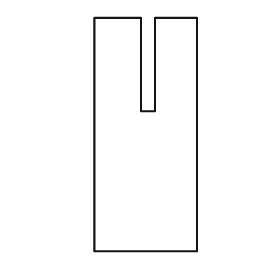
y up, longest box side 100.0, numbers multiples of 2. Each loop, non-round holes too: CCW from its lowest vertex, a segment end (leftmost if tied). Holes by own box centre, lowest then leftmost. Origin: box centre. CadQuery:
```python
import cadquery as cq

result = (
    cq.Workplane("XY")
    .moveTo(-22.0, -50.0)
    .lineTo(22.0, -50.0)
    .lineTo(22.0, 50.0)
    .lineTo(4.0, 50.0)
    .lineTo(4.0, 10.0)
    .lineTo(-2.0, 10.0)
    .lineTo(-2.0, 50.0)
    .lineTo(-22.0, 50.0)
    .close()
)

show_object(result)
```